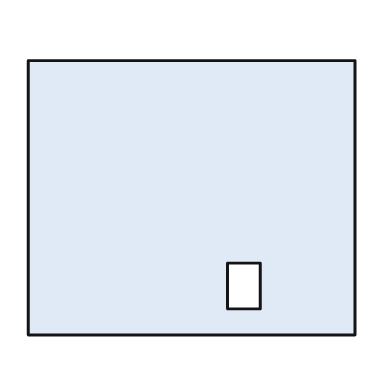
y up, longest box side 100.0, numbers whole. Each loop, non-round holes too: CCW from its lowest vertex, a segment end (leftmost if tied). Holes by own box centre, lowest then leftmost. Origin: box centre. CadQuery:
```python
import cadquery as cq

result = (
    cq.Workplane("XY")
    .moveTo(-50.0, -42.0)
    .lineTo(50.0, -42.0)
    .lineTo(50.0, 42.0)
    .lineTo(-50.0, 42.0)
    .close()
    .moveTo(11.0, -34.0)
    .lineTo(21.0, -34.0)
    .lineTo(21.0, -20.0)
    .lineTo(11.0, -20.0)
    .close()
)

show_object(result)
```